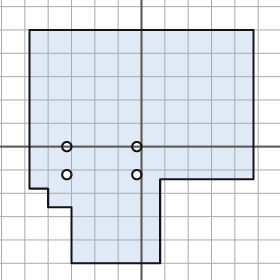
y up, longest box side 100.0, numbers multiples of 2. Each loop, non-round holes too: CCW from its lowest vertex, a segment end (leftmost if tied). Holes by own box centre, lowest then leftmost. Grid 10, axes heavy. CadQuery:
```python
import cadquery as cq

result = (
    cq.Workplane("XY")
    .moveTo(-30.0, -50.0)
    .lineTo(8.0, -50.0)
    .lineTo(8.0, -14.0)
    .lineTo(48.0, -14.0)
    .lineTo(48.0, 50.0)
    .lineTo(-48.0, 50.0)
    .lineTo(-48.0, -18.0)
    .lineTo(-40.0, -18.0)
    .lineTo(-40.0, -26.0)
    .lineTo(-30.0, -26.0)
    .close()
    .moveTo(-32.0, -12.0)
    .circle(2.0)
    .moveTo(-2.0, -12.0)
    .circle(2.0)
    .moveTo(-32.0, 0.0)
    .circle(2.0)
    .moveTo(-2.0, 0.0)
    .circle(2.0)
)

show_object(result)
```